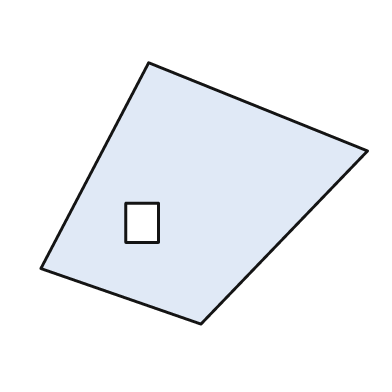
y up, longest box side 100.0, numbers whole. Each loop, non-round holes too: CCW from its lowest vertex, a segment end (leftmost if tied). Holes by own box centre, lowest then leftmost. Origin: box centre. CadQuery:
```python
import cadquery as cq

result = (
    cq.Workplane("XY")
    .moveTo(-1.0, -40.0)
    .lineTo(50.0, 13.0)
    .lineTo(-17.0, 40.0)
    .lineTo(-50.0, -23.0)
    .close()
    .moveTo(-24.0, -15.0)
    .lineTo(-14.0, -15.0)
    .lineTo(-14.0, -3.0)
    .lineTo(-24.0, -3.0)
    .close()
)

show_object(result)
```